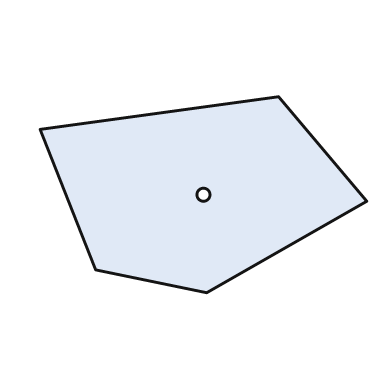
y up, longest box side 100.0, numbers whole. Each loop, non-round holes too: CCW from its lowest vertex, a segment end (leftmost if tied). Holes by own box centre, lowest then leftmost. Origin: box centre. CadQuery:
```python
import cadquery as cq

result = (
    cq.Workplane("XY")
    .moveTo(1.0, -30.0)
    .lineTo(50.0, -2.0)
    .lineTo(23.0, 30.0)
    .lineTo(-50.0, 20.0)
    .lineTo(-33.0, -23.0)
    .close()
    .moveTo(0.0, 0.0)
    .circle(2.0)
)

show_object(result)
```